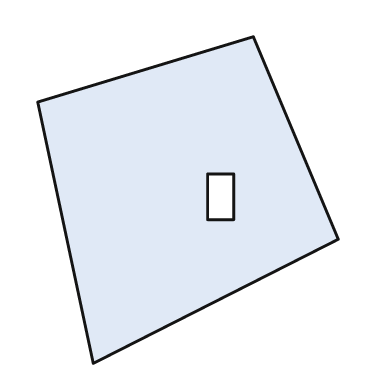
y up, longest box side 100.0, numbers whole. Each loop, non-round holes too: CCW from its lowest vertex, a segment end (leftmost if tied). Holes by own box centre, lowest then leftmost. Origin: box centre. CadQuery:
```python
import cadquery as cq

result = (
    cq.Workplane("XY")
    .moveTo(-29.0, -50.0)
    .lineTo(46.0, -12.0)
    .lineTo(20.0, 50.0)
    .lineTo(-46.0, 30.0)
    .close()
    .moveTo(6.0, -6.0)
    .lineTo(14.0, -6.0)
    .lineTo(14.0, 8.0)
    .lineTo(6.0, 8.0)
    .close()
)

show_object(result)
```